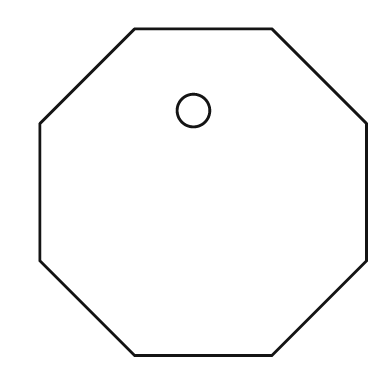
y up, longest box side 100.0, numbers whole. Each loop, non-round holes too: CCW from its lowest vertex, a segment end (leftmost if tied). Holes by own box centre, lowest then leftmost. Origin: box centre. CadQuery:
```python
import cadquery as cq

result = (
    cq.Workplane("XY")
    .moveTo(-21.0, -50.0)
    .lineTo(21.0, -50.0)
    .lineTo(50.0, -21.0)
    .lineTo(50.0, 21.0)
    .lineTo(21.0, 50.0)
    .lineTo(-21.0, 50.0)
    .lineTo(-50.0, 21.0)
    .lineTo(-50.0, -21.0)
    .close()
    .moveTo(-3.0, 25.0)
    .circle(5.0)
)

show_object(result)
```